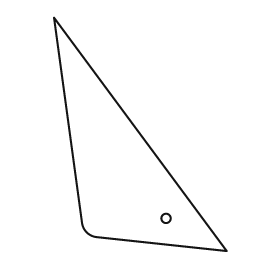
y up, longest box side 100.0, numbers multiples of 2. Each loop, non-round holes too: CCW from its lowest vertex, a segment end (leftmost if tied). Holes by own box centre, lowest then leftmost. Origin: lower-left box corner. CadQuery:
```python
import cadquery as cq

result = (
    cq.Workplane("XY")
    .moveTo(74.0, 0.0)
    .lineTo(0.0, 100.0)
    .lineTo(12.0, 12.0)
    .threePointArc((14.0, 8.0), (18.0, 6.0))
    .close()
    .moveTo(48.0, 14.0)
    .circle(2.0)
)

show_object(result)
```